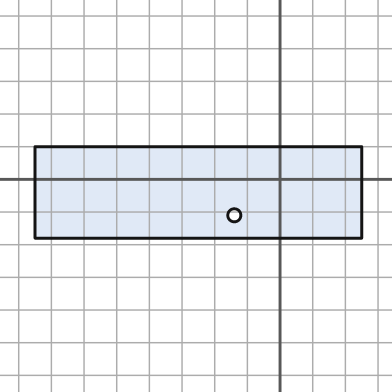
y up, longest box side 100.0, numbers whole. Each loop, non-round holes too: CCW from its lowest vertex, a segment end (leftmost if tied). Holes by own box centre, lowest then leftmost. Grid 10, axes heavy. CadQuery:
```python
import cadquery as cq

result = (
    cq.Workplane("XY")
    .moveTo(-75.0, -18.0)
    .lineTo(25.0, -18.0)
    .lineTo(25.0, 10.0)
    .lineTo(-75.0, 10.0)
    .close()
    .moveTo(-14.0, -11.0)
    .circle(2.0)
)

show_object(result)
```